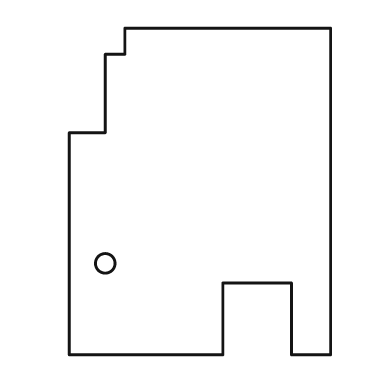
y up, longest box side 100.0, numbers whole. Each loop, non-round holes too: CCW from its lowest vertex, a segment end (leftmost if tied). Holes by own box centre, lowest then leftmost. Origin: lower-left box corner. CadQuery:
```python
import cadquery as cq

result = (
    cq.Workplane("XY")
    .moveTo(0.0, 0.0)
    .lineTo(47.0, 0.0)
    .lineTo(47.0, 22.0)
    .lineTo(68.0, 22.0)
    .lineTo(68.0, 0.0)
    .lineTo(80.0, 0.0)
    .lineTo(80.0, 100.0)
    .lineTo(17.0, 100.0)
    .lineTo(17.0, 92.0)
    .lineTo(11.0, 92.0)
    .lineTo(11.0, 68.0)
    .lineTo(0.0, 68.0)
    .close()
    .moveTo(11.0, 28.0)
    .circle(3.0)
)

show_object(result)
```